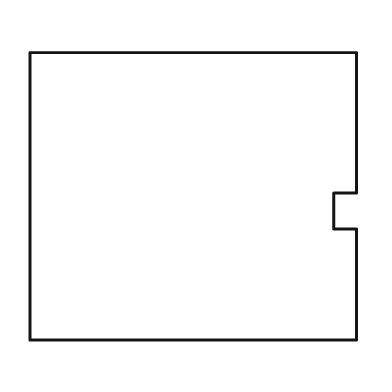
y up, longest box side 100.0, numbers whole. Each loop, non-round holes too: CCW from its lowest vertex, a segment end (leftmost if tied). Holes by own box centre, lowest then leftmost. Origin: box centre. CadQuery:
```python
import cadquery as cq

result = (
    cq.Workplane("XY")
    .moveTo(-50.0, -44.0)
    .lineTo(50.0, -44.0)
    .lineTo(50.0, -10.0)
    .lineTo(43.0, -10.0)
    .lineTo(43.0, 1.0)
    .lineTo(50.0, 1.0)
    .lineTo(50.0, 44.0)
    .lineTo(-50.0, 44.0)
    .close()
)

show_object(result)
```